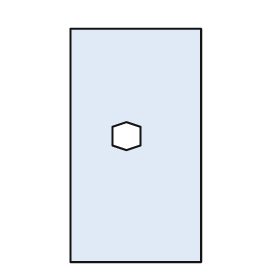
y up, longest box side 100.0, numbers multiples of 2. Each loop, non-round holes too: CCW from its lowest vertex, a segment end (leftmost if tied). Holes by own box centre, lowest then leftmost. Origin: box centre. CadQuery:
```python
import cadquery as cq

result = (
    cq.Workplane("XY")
    .moveTo(-28.0, -50.0)
    .lineTo(28.0, -50.0)
    .lineTo(28.0, 50.0)
    .lineTo(-28.0, 50.0)
    .close()
    .moveTo(-4.0, -2.0)
    .lineTo(2.0, 0.0)
    .lineTo(2.0, 8.0)
    .lineTo(-4.0, 10.0)
    .lineTo(-10.0, 8.0)
    .lineTo(-10.0, 0.0)
    .close()
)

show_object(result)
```